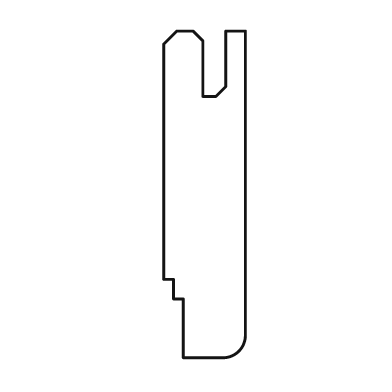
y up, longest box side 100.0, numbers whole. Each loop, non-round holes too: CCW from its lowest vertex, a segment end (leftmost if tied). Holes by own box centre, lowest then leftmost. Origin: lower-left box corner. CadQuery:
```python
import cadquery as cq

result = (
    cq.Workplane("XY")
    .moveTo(6.0, 0.0)
    .lineTo(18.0, 0.0)
    .threePointArc((23.0, 2.0), (25.0, 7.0))
    .lineTo(25.0, 100.0)
    .lineTo(19.0, 100.0)
    .lineTo(19.0, 83.0)
    .lineTo(16.0, 80.0)
    .lineTo(12.0, 80.0)
    .lineTo(12.0, 97.0)
    .lineTo(9.0, 100.0)
    .lineTo(4.0, 100.0)
    .lineTo(0.0, 96.0)
    .lineTo(0.0, 24.0)
    .lineTo(3.0, 24.0)
    .lineTo(3.0, 18.0)
    .lineTo(6.0, 18.0)
    .close()
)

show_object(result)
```